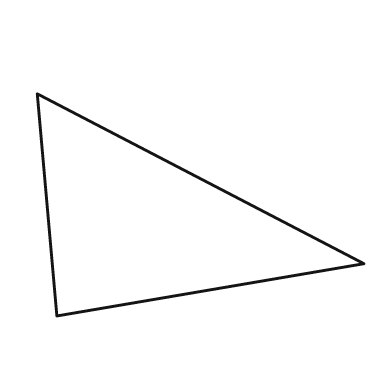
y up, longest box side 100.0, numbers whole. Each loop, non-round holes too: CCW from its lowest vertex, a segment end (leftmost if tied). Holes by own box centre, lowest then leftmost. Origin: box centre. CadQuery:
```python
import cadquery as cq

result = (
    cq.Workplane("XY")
    .moveTo(-44.0, -34.0)
    .lineTo(50.0, -18.0)
    .lineTo(-50.0, 34.0)
    .close()
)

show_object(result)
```